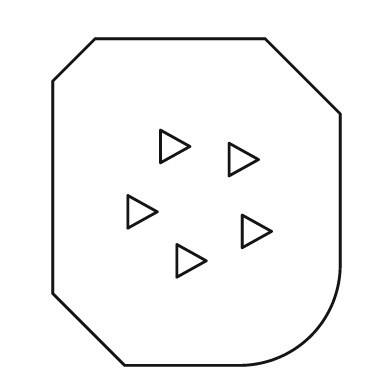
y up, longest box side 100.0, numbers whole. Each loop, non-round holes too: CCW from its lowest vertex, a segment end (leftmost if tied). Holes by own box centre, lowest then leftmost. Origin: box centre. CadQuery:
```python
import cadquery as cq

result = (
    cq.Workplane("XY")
    .moveTo(-22.0, -50.0)
    .lineTo(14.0, -50.0)
    .threePointArc((35.0, -41.0), (44.0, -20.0))
    .lineTo(44.0, 27.0)
    .lineTo(21.0, 50.0)
    .lineTo(-31.0, 50.0)
    .lineTo(-44.0, 37.0)
    .lineTo(-44.0, -28.0)
    .close()
    .moveTo(-6.0, -23.0)
    .lineTo(3.0, -18.0)
    .lineTo(-6.0, -13.0)
    .close()
    .moveTo(14.0, -14.0)
    .lineTo(23.0, -9.0)
    .lineTo(14.0, -4.0)
    .close()
    .moveTo(-21.0, -8.0)
    .lineTo(-12.0, -3.0)
    .lineTo(-21.0, 2.0)
    .close()
    .moveTo(10.0, 8.0)
    .lineTo(19.0, 13.0)
    .lineTo(10.0, 18.0)
    .close()
    .moveTo(-11.0, 12.0)
    .lineTo(-2.0, 17.0)
    .lineTo(-11.0, 22.0)
    .close()
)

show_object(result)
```